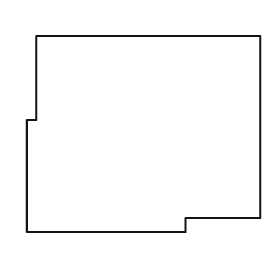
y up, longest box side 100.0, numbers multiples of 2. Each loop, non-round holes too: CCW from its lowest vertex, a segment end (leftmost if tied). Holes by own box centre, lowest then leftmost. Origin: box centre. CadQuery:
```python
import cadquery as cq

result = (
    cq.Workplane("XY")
    .moveTo(-50.0, -42.0)
    .lineTo(18.0, -42.0)
    .lineTo(18.0, -36.0)
    .lineTo(50.0, -36.0)
    .lineTo(50.0, 42.0)
    .lineTo(-46.0, 42.0)
    .lineTo(-46.0, 6.0)
    .lineTo(-50.0, 6.0)
    .close()
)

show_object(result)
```